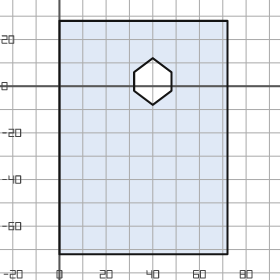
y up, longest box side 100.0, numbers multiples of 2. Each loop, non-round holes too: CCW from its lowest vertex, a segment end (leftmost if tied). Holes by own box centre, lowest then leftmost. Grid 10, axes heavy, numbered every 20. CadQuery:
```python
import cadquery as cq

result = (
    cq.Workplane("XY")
    .moveTo(0.0, -72.0)
    .lineTo(72.0, -72.0)
    .lineTo(72.0, 28.0)
    .lineTo(0.0, 28.0)
    .close()
    .moveTo(40.0, -8.0)
    .lineTo(48.0, -2.0)
    .lineTo(48.0, 6.0)
    .lineTo(40.0, 12.0)
    .lineTo(32.0, 6.0)
    .lineTo(32.0, -2.0)
    .close()
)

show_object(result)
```